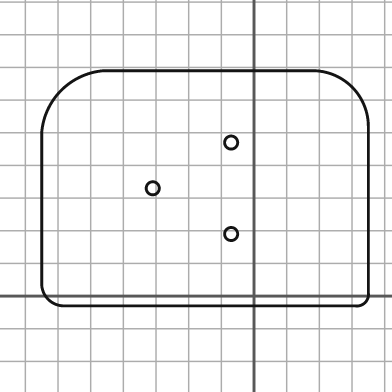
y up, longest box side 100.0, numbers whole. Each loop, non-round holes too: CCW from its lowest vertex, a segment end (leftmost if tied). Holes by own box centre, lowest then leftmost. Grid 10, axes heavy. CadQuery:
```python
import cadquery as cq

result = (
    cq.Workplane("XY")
    .moveTo(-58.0, -3.0)
    .lineTo(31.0, -3.0)
    .threePointArc((34.0, -2.0), (35.0, 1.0))
    .lineTo(35.0, 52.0)
    .threePointArc((30.0, 64.0), (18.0, 69.0))
    .lineTo(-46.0, 69.0)
    .threePointArc((-59.0, 63.0), (-65.0, 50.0))
    .lineTo(-65.0, 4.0)
    .threePointArc((-63.0, -1.0), (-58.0, -3.0))
    .close()
    .moveTo(-7.0, 19.0)
    .circle(2.0)
    .moveTo(-31.0, 33.0)
    .circle(2.0)
    .moveTo(-7.0, 47.0)
    .circle(2.0)
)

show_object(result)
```